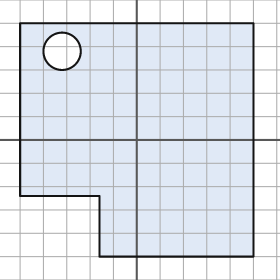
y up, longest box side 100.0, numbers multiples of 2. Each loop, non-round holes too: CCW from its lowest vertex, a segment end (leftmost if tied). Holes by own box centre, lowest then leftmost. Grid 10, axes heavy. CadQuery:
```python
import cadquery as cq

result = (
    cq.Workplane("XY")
    .moveTo(-16.0, -50.0)
    .lineTo(50.0, -50.0)
    .lineTo(50.0, 50.0)
    .lineTo(-50.0, 50.0)
    .lineTo(-50.0, -24.0)
    .lineTo(-16.0, -24.0)
    .close()
    .moveTo(-32.0, 38.0)
    .circle(8.0)
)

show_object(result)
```